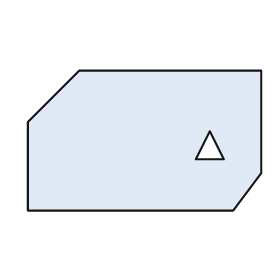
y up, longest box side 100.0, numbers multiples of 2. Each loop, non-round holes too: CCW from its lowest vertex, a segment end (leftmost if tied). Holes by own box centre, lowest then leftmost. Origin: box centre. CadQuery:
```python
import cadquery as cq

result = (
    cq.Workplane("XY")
    .moveTo(-50.0, -30.0)
    .lineTo(38.0, -30.0)
    .lineTo(50.0, -14.0)
    .lineTo(50.0, 30.0)
    .lineTo(-28.0, 30.0)
    .lineTo(-50.0, 8.0)
    .close()
    .moveTo(22.0, -8.0)
    .lineTo(34.0, -8.0)
    .lineTo(28.0, 4.0)
    .close()
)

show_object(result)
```